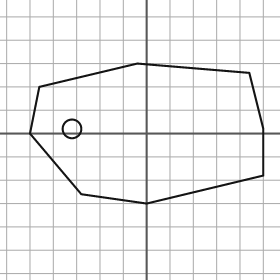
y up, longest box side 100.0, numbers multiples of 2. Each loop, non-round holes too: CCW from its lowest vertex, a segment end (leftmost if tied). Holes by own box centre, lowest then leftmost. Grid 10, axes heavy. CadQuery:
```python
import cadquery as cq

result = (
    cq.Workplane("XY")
    .moveTo(0.0, -30.0)
    .lineTo(50.0, -18.0)
    .lineTo(50.0, 2.0)
    .lineTo(44.0, 26.0)
    .lineTo(-4.0, 30.0)
    .lineTo(-46.0, 20.0)
    .lineTo(-50.0, 0.0)
    .lineTo(-28.0, -26.0)
    .close()
    .moveTo(-32.0, 2.0)
    .circle(4.0)
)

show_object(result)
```